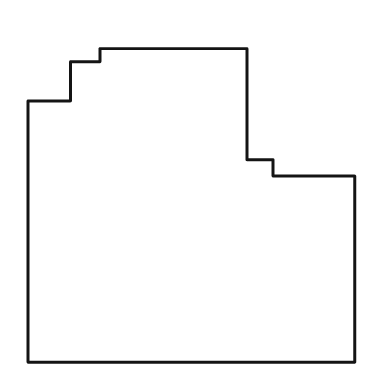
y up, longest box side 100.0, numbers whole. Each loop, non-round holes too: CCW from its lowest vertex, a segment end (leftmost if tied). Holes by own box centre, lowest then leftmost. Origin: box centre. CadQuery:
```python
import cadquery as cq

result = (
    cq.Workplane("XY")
    .moveTo(-50.0, -48.0)
    .lineTo(50.0, -48.0)
    .lineTo(50.0, 9.0)
    .lineTo(25.0, 9.0)
    .lineTo(25.0, 14.0)
    .lineTo(17.0, 14.0)
    .lineTo(17.0, 48.0)
    .lineTo(-28.0, 48.0)
    .lineTo(-28.0, 44.0)
    .lineTo(-37.0, 44.0)
    .lineTo(-37.0, 32.0)
    .lineTo(-50.0, 32.0)
    .close()
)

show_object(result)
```